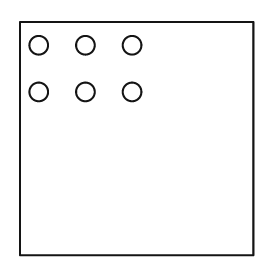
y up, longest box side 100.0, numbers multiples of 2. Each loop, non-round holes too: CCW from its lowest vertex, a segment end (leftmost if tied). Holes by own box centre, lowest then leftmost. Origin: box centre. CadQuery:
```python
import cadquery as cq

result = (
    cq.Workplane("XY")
    .moveTo(-50.0, -50.0)
    .lineTo(50.0, -50.0)
    .lineTo(50.0, 50.0)
    .lineTo(-50.0, 50.0)
    .close()
    .moveTo(-42.0, 20.0)
    .circle(4.0)
    .moveTo(-22.0, 20.0)
    .circle(4.0)
    .moveTo(-2.0, 20.0)
    .circle(4.0)
    .moveTo(-42.0, 40.0)
    .circle(4.0)
    .moveTo(-22.0, 40.0)
    .circle(4.0)
    .moveTo(-2.0, 40.0)
    .circle(4.0)
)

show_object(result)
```